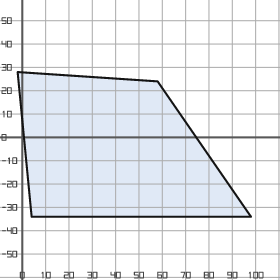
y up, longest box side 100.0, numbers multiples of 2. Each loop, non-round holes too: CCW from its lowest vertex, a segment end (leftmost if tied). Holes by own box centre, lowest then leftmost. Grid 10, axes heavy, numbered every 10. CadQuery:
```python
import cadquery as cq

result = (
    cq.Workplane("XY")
    .moveTo(4.0, -34.0)
    .lineTo(98.0, -34.0)
    .lineTo(58.0, 24.0)
    .lineTo(-2.0, 28.0)
    .close()
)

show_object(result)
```